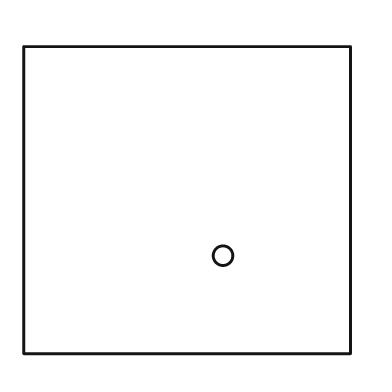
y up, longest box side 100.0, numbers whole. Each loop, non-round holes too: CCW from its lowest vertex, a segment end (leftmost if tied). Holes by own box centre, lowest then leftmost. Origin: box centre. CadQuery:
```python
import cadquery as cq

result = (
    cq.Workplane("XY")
    .moveTo(-50.0, -47.0)
    .lineTo(50.0, -47.0)
    .lineTo(50.0, 47.0)
    .lineTo(-50.0, 47.0)
    .close()
    .moveTo(11.0, -17.0)
    .circle(3.0)
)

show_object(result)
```